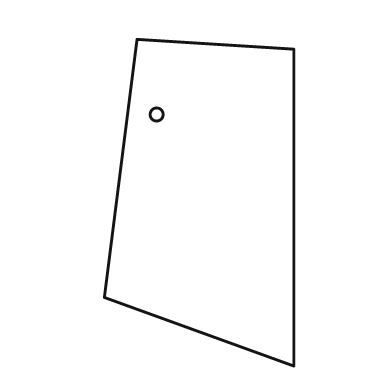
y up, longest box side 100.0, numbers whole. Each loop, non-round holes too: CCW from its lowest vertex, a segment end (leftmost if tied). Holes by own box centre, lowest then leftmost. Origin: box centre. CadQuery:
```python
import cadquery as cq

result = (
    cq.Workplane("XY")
    .moveTo(29.0, -50.0)
    .lineTo(29.0, 47.0)
    .lineTo(-19.0, 50.0)
    .lineTo(-29.0, -29.0)
    .close()
    .moveTo(-13.0, 27.0)
    .circle(2.0)
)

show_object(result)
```